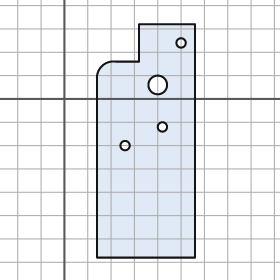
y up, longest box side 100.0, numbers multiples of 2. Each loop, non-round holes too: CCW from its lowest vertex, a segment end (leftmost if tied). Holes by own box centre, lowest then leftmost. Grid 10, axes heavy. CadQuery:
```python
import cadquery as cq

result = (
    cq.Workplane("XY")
    .moveTo(14.0, -68.0)
    .lineTo(56.0, -68.0)
    .lineTo(56.0, 32.0)
    .lineTo(32.0, 32.0)
    .lineTo(32.0, 16.0)
    .lineTo(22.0, 16.0)
    .threePointArc((16.0, 14.0), (14.0, 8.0))
    .close()
    .moveTo(26.0, -20.0)
    .circle(2.0)
    .moveTo(42.0, -12.0)
    .circle(2.0)
    .moveTo(40.0, 6.0)
    .circle(4.0)
    .moveTo(50.0, 24.0)
    .circle(2.0)
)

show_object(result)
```